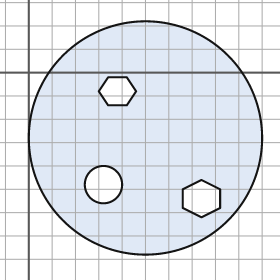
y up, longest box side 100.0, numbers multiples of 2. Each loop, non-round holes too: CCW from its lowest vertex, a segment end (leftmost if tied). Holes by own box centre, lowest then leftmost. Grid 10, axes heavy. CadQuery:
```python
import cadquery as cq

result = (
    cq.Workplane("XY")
    .moveTo(50.0, -28.0)
    .circle(50.0)
    .moveTo(74.0, -62.0)
    .lineTo(82.0, -58.0)
    .lineTo(82.0, -50.0)
    .lineTo(74.0, -46.0)
    .lineTo(66.0, -50.0)
    .lineTo(66.0, -58.0)
    .close()
    .moveTo(32.0, -48.0)
    .circle(8.0)
    .moveTo(34.0, -14.0)
    .lineTo(42.0, -14.0)
    .lineTo(46.0, -8.0)
    .lineTo(42.0, -2.0)
    .lineTo(34.0, -2.0)
    .lineTo(30.0, -8.0)
    .close()
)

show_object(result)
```